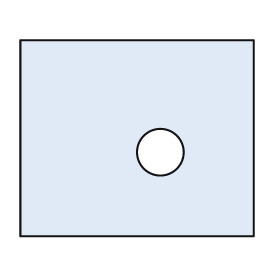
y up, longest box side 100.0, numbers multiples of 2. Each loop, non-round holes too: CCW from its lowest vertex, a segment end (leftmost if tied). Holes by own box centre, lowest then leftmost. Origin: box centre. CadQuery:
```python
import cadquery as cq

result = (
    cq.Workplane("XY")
    .moveTo(-50.0, -42.0)
    .lineTo(50.0, -42.0)
    .lineTo(50.0, 42.0)
    .lineTo(-50.0, 42.0)
    .close()
    .moveTo(10.0, -6.0)
    .circle(10.0)
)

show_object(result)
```